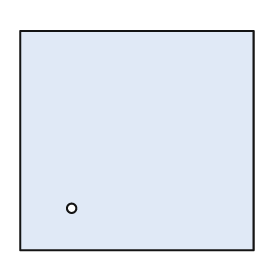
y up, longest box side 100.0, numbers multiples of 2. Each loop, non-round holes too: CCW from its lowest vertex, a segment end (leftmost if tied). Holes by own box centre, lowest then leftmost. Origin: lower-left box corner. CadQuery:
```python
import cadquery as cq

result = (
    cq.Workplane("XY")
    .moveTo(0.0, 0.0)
    .lineTo(100.0, 0.0)
    .lineTo(100.0, 94.0)
    .lineTo(0.0, 94.0)
    .close()
    .moveTo(22.0, 18.0)
    .circle(2.0)
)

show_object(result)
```